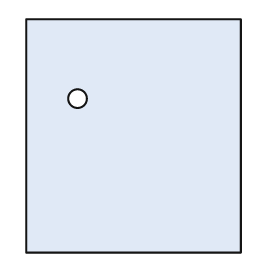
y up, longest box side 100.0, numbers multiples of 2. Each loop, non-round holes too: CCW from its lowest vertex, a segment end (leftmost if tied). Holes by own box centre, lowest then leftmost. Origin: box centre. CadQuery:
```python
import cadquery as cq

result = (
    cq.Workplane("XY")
    .moveTo(-46.0, -50.0)
    .lineTo(46.0, -50.0)
    .lineTo(46.0, 50.0)
    .lineTo(-46.0, 50.0)
    .close()
    .moveTo(-24.0, 16.0)
    .circle(4.0)
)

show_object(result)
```